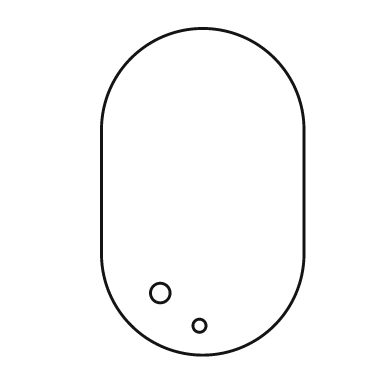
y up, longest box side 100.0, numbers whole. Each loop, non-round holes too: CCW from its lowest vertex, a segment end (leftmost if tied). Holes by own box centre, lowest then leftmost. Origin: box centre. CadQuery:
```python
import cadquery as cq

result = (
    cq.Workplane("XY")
    .moveTo(-31.0, -19.0)
    .threePointArc((0.0, -50.0), (31.0, -19.0))
    .lineTo(31.0, 19.0)
    .threePointArc((0.0, 50.0), (-31.0, 19.0))
    .close()
    .moveTo(-1.0, -41.0)
    .circle(2.0)
    .moveTo(-13.0, -31.0)
    .circle(3.0)
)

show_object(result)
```